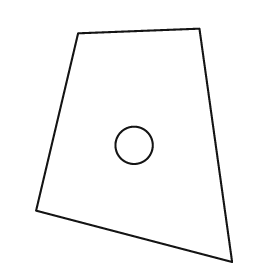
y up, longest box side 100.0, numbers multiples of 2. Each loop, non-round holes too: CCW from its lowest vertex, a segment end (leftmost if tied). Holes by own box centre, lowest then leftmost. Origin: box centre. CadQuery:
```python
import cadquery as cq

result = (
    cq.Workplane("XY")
    .moveTo(42.0, -50.0)
    .lineTo(28.0, 50.0)
    .lineTo(-24.0, 48.0)
    .lineTo(-42.0, -28.0)
    .close()
    .moveTo(0.0, 0.0)
    .circle(8.0)
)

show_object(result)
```